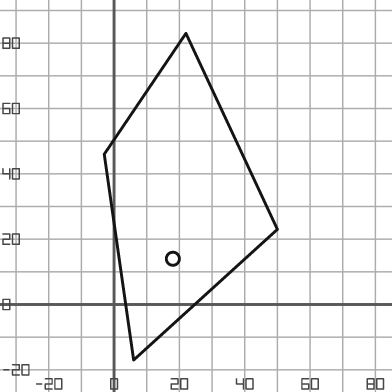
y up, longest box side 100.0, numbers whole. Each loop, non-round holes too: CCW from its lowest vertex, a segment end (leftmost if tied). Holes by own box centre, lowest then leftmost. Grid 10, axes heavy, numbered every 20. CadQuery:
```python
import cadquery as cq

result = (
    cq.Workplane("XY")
    .moveTo(6.0, -17.0)
    .lineTo(50.0, 23.0)
    .lineTo(22.0, 83.0)
    .lineTo(-3.0, 46.0)
    .close()
    .moveTo(18.0, 14.0)
    .circle(2.0)
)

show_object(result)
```